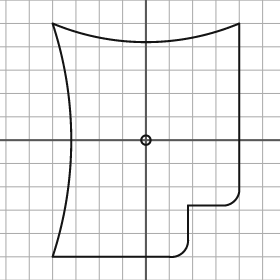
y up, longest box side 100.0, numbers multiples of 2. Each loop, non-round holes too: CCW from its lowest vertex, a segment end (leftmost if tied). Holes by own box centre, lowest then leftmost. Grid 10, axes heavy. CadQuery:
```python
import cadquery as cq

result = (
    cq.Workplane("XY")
    .moveTo(-40.0, -50.0)
    .lineTo(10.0, -50.0)
    .threePointArc((16.0, -48.0), (18.0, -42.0))
    .lineTo(18.0, -28.0)
    .lineTo(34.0, -28.0)
    .threePointArc((38.0, -26.0), (40.0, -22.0))
    .lineTo(40.0, 50.0)
    .threePointArc((0.0, 42.0), (-40.0, 50.0))
    .threePointArc((-32.0, 0.0), (-40.0, -50.0))
    .close()
    .moveTo(0.0, 0.0)
    .circle(2.0)
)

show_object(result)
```